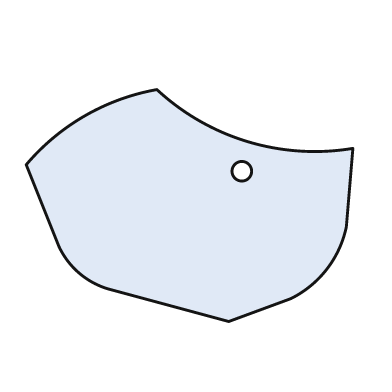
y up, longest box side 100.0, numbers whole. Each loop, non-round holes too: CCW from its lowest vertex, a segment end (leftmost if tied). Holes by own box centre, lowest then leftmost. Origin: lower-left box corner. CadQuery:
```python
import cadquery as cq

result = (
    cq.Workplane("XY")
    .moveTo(62.0, 0.0)
    .lineTo(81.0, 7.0)
    .threePointArc((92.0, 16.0), (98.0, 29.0))
    .lineTo(100.0, 53.0)
    .threePointArc((68.0, 55.0), (40.0, 71.0))
    .threePointArc((18.0, 63.0), (0.0, 48.0))
    .lineTo(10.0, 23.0)
    .threePointArc((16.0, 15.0), (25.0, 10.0))
    .close()
    .moveTo(66.0, 46.0)
    .circle(3.0)
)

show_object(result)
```